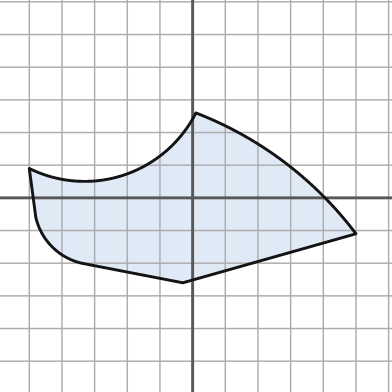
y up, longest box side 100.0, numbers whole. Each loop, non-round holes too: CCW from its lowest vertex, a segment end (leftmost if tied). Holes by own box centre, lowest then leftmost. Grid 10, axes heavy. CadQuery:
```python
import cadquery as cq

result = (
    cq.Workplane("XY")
    .moveTo(-3.0, -26.0)
    .lineTo(50.0, -11.0)
    .threePointArc((28.0, 11.0), (1.0, 26.0))
    .threePointArc((-21.0, 7.0), (-50.0, 9.0))
    .lineTo(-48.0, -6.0)
    .threePointArc((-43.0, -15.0), (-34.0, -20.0))
    .close()
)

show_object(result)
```